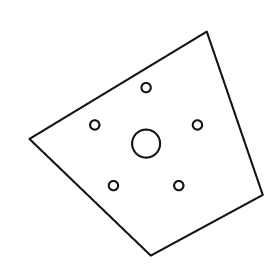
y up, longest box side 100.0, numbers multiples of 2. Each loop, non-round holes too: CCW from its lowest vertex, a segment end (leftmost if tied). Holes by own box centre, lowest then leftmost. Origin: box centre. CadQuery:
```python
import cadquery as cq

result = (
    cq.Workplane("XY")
    .moveTo(2.0, -48.0)
    .lineTo(50.0, -22.0)
    .lineTo(26.0, 48.0)
    .lineTo(-50.0, 2.0)
    .close()
    .moveTo(-14.0, -18.0)
    .circle(2.0)
    .moveTo(14.0, -18.0)
    .circle(2.0)
    .moveTo(0.0, 0.0)
    .circle(6.0)
    .moveTo(-22.0, 8.0)
    .circle(2.0)
    .moveTo(22.0, 8.0)
    .circle(2.0)
    .moveTo(0.0, 24.0)
    .circle(2.0)
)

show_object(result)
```